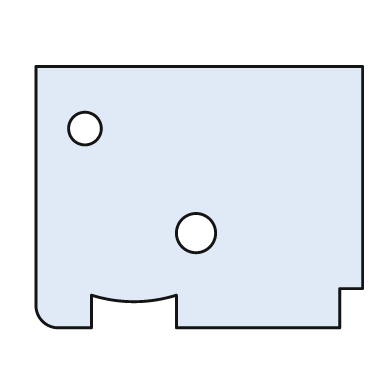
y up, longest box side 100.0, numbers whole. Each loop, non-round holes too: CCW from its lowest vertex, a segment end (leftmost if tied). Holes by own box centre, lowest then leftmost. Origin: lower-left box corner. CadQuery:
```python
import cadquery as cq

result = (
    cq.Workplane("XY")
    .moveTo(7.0, 0.0)
    .lineTo(17.0, 0.0)
    .lineTo(17.0, 10.0)
    .threePointArc((30.0, 8.0), (43.0, 10.0))
    .lineTo(43.0, 0.0)
    .lineTo(93.0, 0.0)
    .lineTo(93.0, 12.0)
    .lineTo(100.0, 12.0)
    .lineTo(100.0, 80.0)
    .lineTo(0.0, 80.0)
    .lineTo(0.0, 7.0)
    .threePointArc((2.0, 2.0), (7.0, 0.0))
    .close()
    .moveTo(49.0, 29.0)
    .circle(6.0)
    .moveTo(15.0, 61.0)
    .circle(5.0)
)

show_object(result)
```